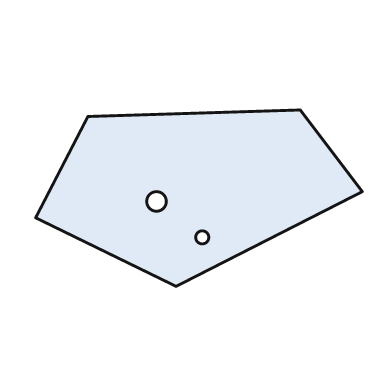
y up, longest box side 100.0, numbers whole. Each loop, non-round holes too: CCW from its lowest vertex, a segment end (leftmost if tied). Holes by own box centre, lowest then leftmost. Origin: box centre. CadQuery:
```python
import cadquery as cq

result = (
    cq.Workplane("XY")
    .moveTo(-7.0, -27.0)
    .lineTo(50.0, 2.0)
    .lineTo(31.0, 27.0)
    .lineTo(-34.0, 25.0)
    .lineTo(-50.0, -6.0)
    .close()
    .moveTo(1.0, -12.0)
    .circle(2.0)
    .moveTo(-13.0, -1.0)
    .circle(3.0)
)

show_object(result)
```